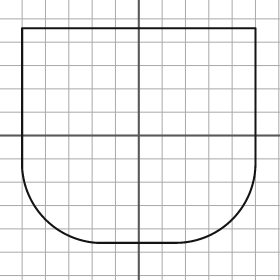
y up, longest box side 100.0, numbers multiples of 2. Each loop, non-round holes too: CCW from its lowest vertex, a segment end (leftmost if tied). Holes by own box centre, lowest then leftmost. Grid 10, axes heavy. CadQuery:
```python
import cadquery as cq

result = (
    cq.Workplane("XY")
    .moveTo(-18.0, -46.0)
    .lineTo(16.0, -46.0)
    .threePointArc((40.0, -36.0), (50.0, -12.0))
    .lineTo(50.0, 46.0)
    .lineTo(-50.0, 46.0)
    .lineTo(-50.0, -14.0)
    .threePointArc((-40.0, -36.0), (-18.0, -46.0))
    .close()
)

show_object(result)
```